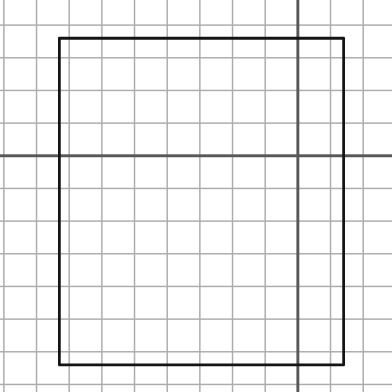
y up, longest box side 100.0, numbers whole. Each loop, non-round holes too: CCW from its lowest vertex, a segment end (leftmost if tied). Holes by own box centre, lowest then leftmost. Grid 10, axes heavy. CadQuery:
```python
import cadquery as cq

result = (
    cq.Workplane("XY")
    .moveTo(-73.0, -64.0)
    .lineTo(14.0, -64.0)
    .lineTo(14.0, 36.0)
    .lineTo(-73.0, 36.0)
    .close()
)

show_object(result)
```